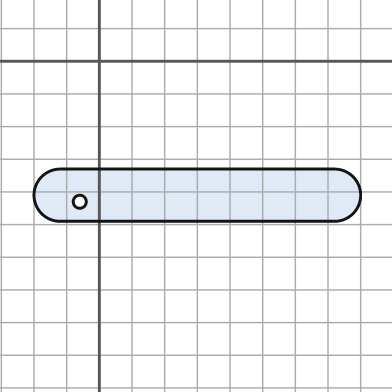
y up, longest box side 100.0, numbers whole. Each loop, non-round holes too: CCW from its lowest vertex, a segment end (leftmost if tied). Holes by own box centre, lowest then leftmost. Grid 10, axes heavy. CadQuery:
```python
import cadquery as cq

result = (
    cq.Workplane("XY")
    .moveTo(-12.0, -49.0)
    .lineTo(72.0, -49.0)
    .threePointArc((80.0, -41.0), (72.0, -33.0))
    .lineTo(-12.0, -33.0)
    .threePointArc((-20.0, -41.0), (-12.0, -49.0))
    .close()
    .moveTo(-6.0, -43.0)
    .circle(2.0)
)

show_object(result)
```